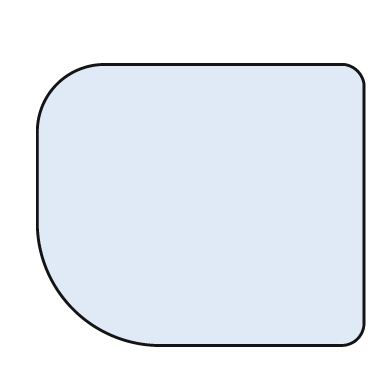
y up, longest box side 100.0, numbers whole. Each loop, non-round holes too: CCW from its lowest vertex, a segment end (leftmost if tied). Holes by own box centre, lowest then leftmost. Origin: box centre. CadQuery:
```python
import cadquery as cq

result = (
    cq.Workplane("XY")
    .moveTo(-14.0, -43.0)
    .lineTo(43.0, -43.0)
    .threePointArc((48.0, -41.0), (50.0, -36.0))
    .lineTo(50.0, 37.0)
    .threePointArc((48.0, 41.0), (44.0, 43.0))
    .lineTo(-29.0, 43.0)
    .threePointArc((-44.0, 37.0), (-50.0, 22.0))
    .lineTo(-50.0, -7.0)
    .threePointArc((-39.0, -32.0), (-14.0, -43.0))
    .close()
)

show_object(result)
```